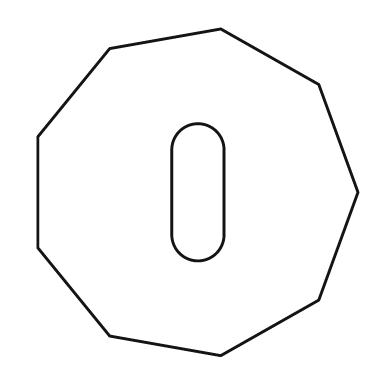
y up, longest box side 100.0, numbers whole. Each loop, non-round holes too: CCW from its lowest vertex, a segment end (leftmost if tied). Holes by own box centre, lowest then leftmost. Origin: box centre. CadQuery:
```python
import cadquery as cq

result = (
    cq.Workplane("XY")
    .moveTo(7.0, -50.0)
    .lineTo(37.0, -33.0)
    .lineTo(49.0, 0.0)
    .lineTo(37.0, 33.0)
    .lineTo(7.0, 50.0)
    .lineTo(-27.0, 44.0)
    .lineTo(-49.0, 17.0)
    .lineTo(-49.0, -17.0)
    .lineTo(-27.0, -44.0)
    .close()
    .moveTo(-8.0, -13.0)
    .threePointArc((0.0, -21.0), (8.0, -13.0))
    .lineTo(8.0, 13.0)
    .threePointArc((0.0, 21.0), (-8.0, 13.0))
    .close()
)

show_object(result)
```